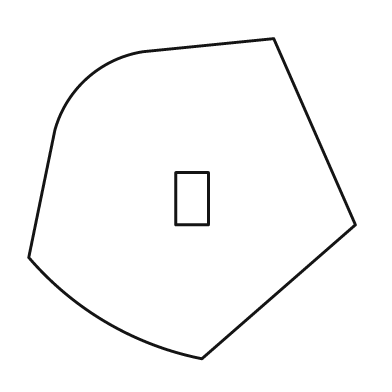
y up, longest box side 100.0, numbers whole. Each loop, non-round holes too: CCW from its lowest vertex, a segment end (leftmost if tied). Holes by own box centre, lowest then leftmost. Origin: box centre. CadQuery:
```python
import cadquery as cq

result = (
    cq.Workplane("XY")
    .moveTo(3.0, -49.0)
    .lineTo(50.0, -8.0)
    .lineTo(25.0, 49.0)
    .lineTo(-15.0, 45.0)
    .threePointArc((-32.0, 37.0), (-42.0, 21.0))
    .lineTo(-50.0, -18.0)
    .threePointArc((-26.0, -38.0), (3.0, -49.0))
    .close()
    .moveTo(-5.0, -8.0)
    .lineTo(5.0, -8.0)
    .lineTo(5.0, 8.0)
    .lineTo(-5.0, 8.0)
    .close()
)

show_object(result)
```